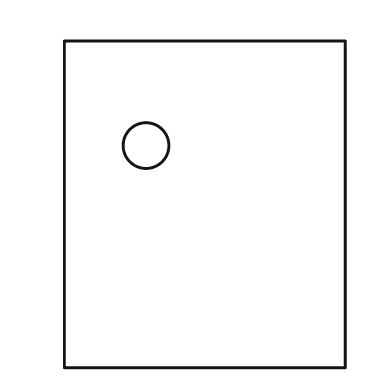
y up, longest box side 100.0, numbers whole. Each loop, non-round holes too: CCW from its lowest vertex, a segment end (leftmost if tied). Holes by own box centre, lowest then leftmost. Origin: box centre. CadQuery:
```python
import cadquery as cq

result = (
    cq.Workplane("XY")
    .moveTo(-43.0, -50.0)
    .lineTo(43.0, -50.0)
    .lineTo(43.0, 50.0)
    .lineTo(-43.0, 50.0)
    .close()
    .moveTo(-18.0, 18.0)
    .circle(7.0)
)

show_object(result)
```